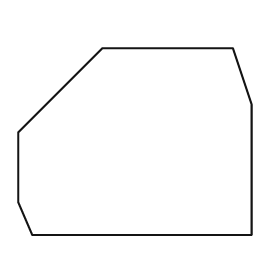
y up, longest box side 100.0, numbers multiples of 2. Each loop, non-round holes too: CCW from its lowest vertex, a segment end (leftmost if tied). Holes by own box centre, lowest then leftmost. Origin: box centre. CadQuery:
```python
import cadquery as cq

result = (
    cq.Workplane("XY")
    .moveTo(-44.0, -40.0)
    .lineTo(50.0, -40.0)
    .lineTo(50.0, 16.0)
    .lineTo(42.0, 40.0)
    .lineTo(-14.0, 40.0)
    .lineTo(-50.0, 4.0)
    .lineTo(-50.0, -26.0)
    .close()
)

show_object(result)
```